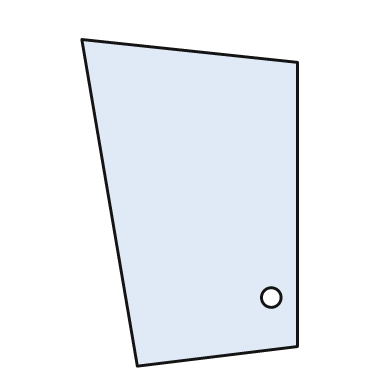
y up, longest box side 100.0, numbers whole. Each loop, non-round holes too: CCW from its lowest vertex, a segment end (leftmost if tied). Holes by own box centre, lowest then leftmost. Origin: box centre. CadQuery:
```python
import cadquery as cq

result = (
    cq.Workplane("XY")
    .moveTo(-16.0, -50.0)
    .lineTo(33.0, -44.0)
    .lineTo(33.0, 43.0)
    .lineTo(-33.0, 50.0)
    .close()
    .moveTo(25.0, -29.0)
    .circle(3.0)
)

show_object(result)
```